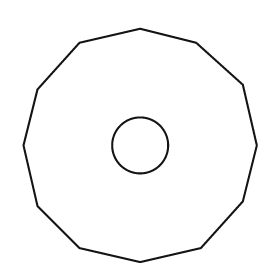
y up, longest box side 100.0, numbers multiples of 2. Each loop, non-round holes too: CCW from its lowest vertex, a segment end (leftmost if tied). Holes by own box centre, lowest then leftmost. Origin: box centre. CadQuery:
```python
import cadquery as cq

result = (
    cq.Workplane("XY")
    .moveTo(0.0, -50.0)
    .lineTo(26.0, -44.0)
    .lineTo(44.0, -24.0)
    .lineTo(50.0, 0.0)
    .lineTo(44.0, 26.0)
    .lineTo(24.0, 44.0)
    .lineTo(0.0, 50.0)
    .lineTo(-26.0, 44.0)
    .lineTo(-44.0, 24.0)
    .lineTo(-50.0, 0.0)
    .lineTo(-44.0, -26.0)
    .lineTo(-26.0, -44.0)
    .close()
    .moveTo(0.0, 0.0)
    .circle(12.0)
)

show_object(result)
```